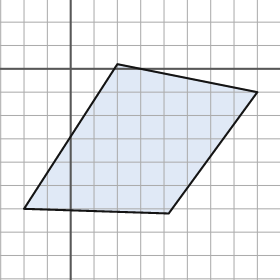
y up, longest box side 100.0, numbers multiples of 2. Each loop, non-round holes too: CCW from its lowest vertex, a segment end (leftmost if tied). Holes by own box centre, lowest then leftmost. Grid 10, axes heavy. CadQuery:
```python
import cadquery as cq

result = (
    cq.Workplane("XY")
    .moveTo(42.0, -62.0)
    .lineTo(80.0, -10.0)
    .lineTo(20.0, 2.0)
    .lineTo(-20.0, -60.0)
    .close()
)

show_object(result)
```